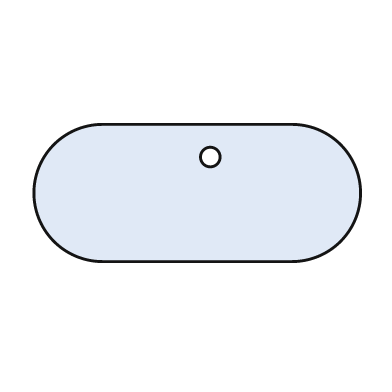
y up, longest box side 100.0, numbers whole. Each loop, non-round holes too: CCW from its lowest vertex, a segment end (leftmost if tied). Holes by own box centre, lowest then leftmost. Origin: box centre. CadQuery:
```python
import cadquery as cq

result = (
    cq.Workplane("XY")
    .moveTo(-29.0, -21.0)
    .lineTo(29.0, -21.0)
    .threePointArc((50.0, 0.0), (29.0, 21.0))
    .lineTo(-29.0, 21.0)
    .threePointArc((-50.0, 0.0), (-29.0, -21.0))
    .close()
    .moveTo(4.0, 11.0)
    .circle(3.0)
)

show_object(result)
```